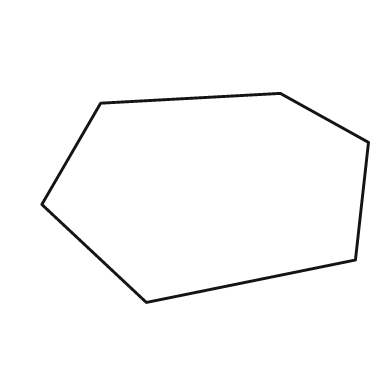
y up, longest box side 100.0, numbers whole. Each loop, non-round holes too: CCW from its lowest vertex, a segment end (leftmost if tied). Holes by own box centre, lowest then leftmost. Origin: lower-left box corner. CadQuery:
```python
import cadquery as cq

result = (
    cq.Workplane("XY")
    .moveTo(32.0, 0.0)
    .lineTo(96.0, 13.0)
    .lineTo(100.0, 49.0)
    .lineTo(73.0, 64.0)
    .lineTo(18.0, 61.0)
    .lineTo(0.0, 30.0)
    .close()
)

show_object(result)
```